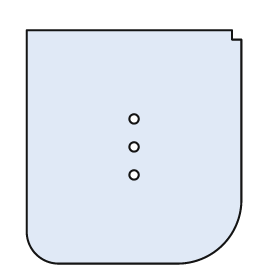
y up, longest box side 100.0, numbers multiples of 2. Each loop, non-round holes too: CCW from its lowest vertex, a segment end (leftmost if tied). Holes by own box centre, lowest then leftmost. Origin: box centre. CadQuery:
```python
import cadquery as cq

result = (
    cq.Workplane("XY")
    .moveTo(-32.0, -50.0)
    .lineTo(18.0, -50.0)
    .threePointArc((38.0, -42.0), (46.0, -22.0))
    .lineTo(46.0, 46.0)
    .lineTo(42.0, 46.0)
    .lineTo(42.0, 50.0)
    .lineTo(-46.0, 50.0)
    .lineTo(-46.0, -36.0)
    .threePointArc((-42.0, -46.0), (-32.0, -50.0))
    .close()
    .moveTo(0.0, -12.0)
    .circle(2.0)
    .moveTo(0.0, 0.0)
    .circle(2.0)
    .moveTo(0.0, 12.0)
    .circle(2.0)
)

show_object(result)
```